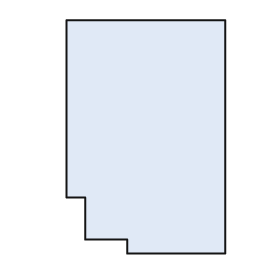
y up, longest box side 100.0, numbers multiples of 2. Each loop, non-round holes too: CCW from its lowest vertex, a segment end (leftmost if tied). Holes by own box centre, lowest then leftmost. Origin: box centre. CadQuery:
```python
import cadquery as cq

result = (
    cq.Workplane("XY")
    .moveTo(-8.0, -50.0)
    .lineTo(34.0, -50.0)
    .lineTo(34.0, 50.0)
    .lineTo(-34.0, 50.0)
    .lineTo(-34.0, -26.0)
    .lineTo(-26.0, -26.0)
    .lineTo(-26.0, -44.0)
    .lineTo(-8.0, -44.0)
    .close()
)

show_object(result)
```